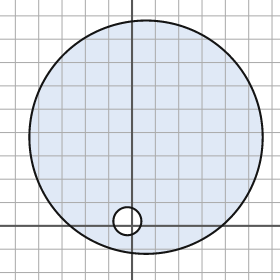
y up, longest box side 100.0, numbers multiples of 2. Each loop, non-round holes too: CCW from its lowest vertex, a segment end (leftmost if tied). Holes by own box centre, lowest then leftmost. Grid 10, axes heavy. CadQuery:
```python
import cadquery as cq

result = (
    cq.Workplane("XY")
    .moveTo(6.0, 38.0)
    .circle(50.0)
    .moveTo(-2.0, 2.0)
    .circle(6.0)
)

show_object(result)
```